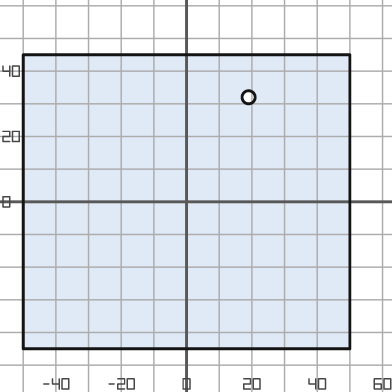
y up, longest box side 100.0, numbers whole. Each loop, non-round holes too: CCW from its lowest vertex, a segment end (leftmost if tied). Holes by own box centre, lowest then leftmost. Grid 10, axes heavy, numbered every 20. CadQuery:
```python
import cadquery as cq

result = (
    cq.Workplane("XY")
    .moveTo(-50.0, -45.0)
    .lineTo(50.0, -45.0)
    .lineTo(50.0, 45.0)
    .lineTo(-50.0, 45.0)
    .close()
    .moveTo(19.0, 32.0)
    .circle(2.0)
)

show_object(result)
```